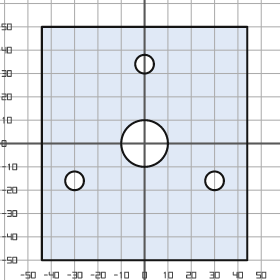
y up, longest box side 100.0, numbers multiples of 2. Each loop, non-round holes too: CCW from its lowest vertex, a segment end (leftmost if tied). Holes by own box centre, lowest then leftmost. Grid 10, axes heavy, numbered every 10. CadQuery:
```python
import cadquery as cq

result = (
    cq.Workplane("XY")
    .moveTo(-44.0, -50.0)
    .lineTo(44.0, -50.0)
    .lineTo(44.0, 50.0)
    .lineTo(-44.0, 50.0)
    .close()
    .moveTo(-30.0, -16.0)
    .circle(4.0)
    .moveTo(30.0, -16.0)
    .circle(4.0)
    .moveTo(0.0, 0.0)
    .circle(10.0)
    .moveTo(0.0, 34.0)
    .circle(4.0)
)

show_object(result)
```